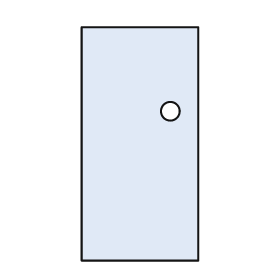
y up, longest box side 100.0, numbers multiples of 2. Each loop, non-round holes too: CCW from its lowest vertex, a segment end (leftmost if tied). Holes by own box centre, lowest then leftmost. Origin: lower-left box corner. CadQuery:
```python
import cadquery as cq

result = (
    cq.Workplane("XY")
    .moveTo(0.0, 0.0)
    .lineTo(50.0, 0.0)
    .lineTo(50.0, 100.0)
    .lineTo(0.0, 100.0)
    .close()
    .moveTo(38.0, 64.0)
    .circle(4.0)
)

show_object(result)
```